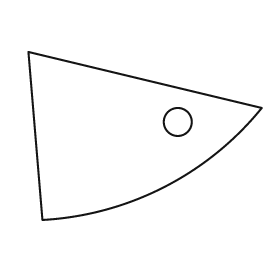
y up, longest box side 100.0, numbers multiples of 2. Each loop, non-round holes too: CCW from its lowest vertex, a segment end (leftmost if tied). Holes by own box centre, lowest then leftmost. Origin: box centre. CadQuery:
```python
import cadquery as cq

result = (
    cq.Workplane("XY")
    .moveTo(-44.0, -36.0)
    .threePointArc((8.0, -22.0), (50.0, 12.0))
    .lineTo(-50.0, 36.0)
    .close()
    .moveTo(14.0, 6.0)
    .circle(6.0)
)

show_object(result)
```